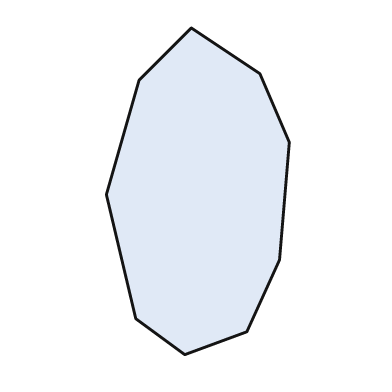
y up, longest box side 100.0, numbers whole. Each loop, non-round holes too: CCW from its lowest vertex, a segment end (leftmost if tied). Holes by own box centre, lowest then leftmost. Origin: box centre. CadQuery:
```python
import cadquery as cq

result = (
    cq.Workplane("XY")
    .moveTo(-4.0, -50.0)
    .lineTo(15.0, -43.0)
    .lineTo(25.0, -21.0)
    .lineTo(28.0, 15.0)
    .lineTo(19.0, 36.0)
    .lineTo(-2.0, 50.0)
    .lineTo(-18.0, 34.0)
    .lineTo(-28.0, -1.0)
    .lineTo(-19.0, -39.0)
    .close()
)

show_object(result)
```